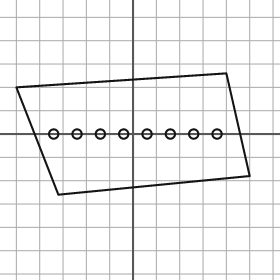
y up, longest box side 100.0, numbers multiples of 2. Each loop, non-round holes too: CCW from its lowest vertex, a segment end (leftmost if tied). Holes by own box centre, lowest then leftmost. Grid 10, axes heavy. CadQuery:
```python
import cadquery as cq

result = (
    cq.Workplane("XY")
    .moveTo(-32.0, -26.0)
    .lineTo(50.0, -18.0)
    .lineTo(40.0, 26.0)
    .lineTo(-50.0, 20.0)
    .close()
    .moveTo(-34.0, 0.0)
    .circle(2.0)
    .moveTo(-24.0, 0.0)
    .circle(2.0)
    .moveTo(-14.0, 0.0)
    .circle(2.0)
    .moveTo(-4.0, 0.0)
    .circle(2.0)
    .moveTo(6.0, 0.0)
    .circle(2.0)
    .moveTo(16.0, 0.0)
    .circle(2.0)
    .moveTo(26.0, 0.0)
    .circle(2.0)
    .moveTo(36.0, 0.0)
    .circle(2.0)
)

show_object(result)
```